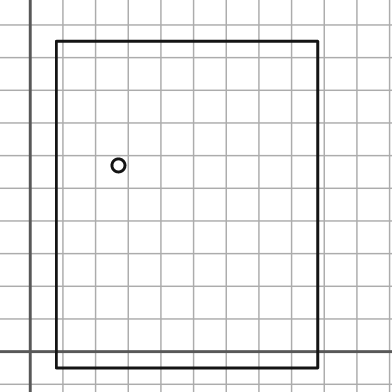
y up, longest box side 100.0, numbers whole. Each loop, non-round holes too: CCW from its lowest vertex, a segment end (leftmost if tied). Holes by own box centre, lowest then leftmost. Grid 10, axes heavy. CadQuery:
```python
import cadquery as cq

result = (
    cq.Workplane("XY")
    .moveTo(8.0, -5.0)
    .lineTo(88.0, -5.0)
    .lineTo(88.0, 95.0)
    .lineTo(8.0, 95.0)
    .close()
    .moveTo(27.0, 57.0)
    .circle(2.0)
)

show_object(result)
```